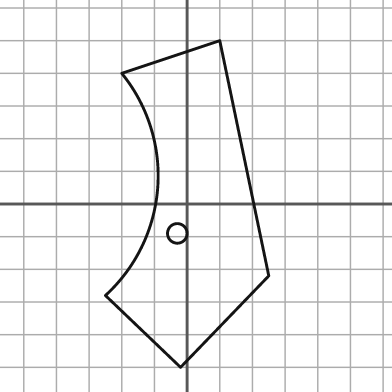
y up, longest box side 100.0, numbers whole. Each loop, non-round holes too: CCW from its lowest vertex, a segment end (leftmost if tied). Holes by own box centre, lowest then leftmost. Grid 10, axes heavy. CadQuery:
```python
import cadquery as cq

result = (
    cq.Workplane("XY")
    .moveTo(-2.0, -50.0)
    .lineTo(25.0, -22.0)
    .lineTo(10.0, 50.0)
    .lineTo(-20.0, 40.0)
    .threePointArc((-9.0, 5.0), (-25.0, -28.0))
    .close()
    .moveTo(-3.0, -9.0)
    .circle(3.0)
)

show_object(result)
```